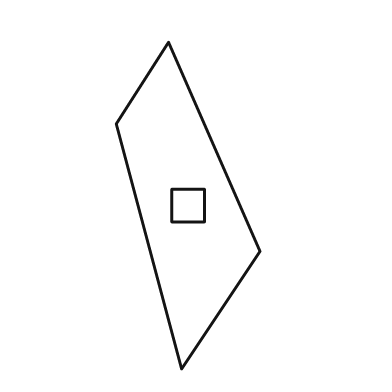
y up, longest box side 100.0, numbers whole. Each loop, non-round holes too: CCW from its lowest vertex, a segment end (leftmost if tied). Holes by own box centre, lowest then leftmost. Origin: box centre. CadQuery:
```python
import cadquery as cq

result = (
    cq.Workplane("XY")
    .moveTo(-2.0, -50.0)
    .lineTo(22.0, -14.0)
    .lineTo(-6.0, 50.0)
    .lineTo(-22.0, 25.0)
    .close()
    .moveTo(-5.0, -5.0)
    .lineTo(5.0, -5.0)
    .lineTo(5.0, 5.0)
    .lineTo(-5.0, 5.0)
    .close()
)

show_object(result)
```